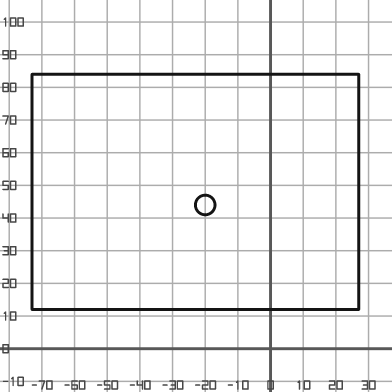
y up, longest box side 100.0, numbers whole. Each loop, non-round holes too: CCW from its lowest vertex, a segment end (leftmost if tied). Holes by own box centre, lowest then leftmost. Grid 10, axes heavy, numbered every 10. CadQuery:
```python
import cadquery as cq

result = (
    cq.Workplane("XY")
    .moveTo(-73.0, 12.0)
    .lineTo(27.0, 12.0)
    .lineTo(27.0, 84.0)
    .lineTo(-73.0, 84.0)
    .close()
    .moveTo(-20.0, 44.0)
    .circle(3.0)
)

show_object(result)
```